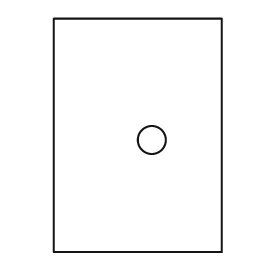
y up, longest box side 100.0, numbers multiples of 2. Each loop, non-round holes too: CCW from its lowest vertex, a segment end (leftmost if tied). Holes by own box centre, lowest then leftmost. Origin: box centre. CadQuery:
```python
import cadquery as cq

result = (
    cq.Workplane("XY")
    .moveTo(-36.0, -50.0)
    .lineTo(36.0, -50.0)
    .lineTo(36.0, 50.0)
    .lineTo(-36.0, 50.0)
    .close()
    .moveTo(6.0, -2.0)
    .circle(6.0)
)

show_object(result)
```